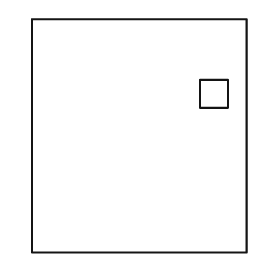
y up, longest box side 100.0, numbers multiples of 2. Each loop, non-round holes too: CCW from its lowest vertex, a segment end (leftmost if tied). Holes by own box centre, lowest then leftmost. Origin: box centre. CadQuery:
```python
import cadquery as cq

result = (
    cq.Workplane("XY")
    .moveTo(-46.0, -50.0)
    .lineTo(46.0, -50.0)
    .lineTo(46.0, 50.0)
    .lineTo(-46.0, 50.0)
    .close()
    .moveTo(26.0, 12.0)
    .lineTo(38.0, 12.0)
    .lineTo(38.0, 24.0)
    .lineTo(26.0, 24.0)
    .close()
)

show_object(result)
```